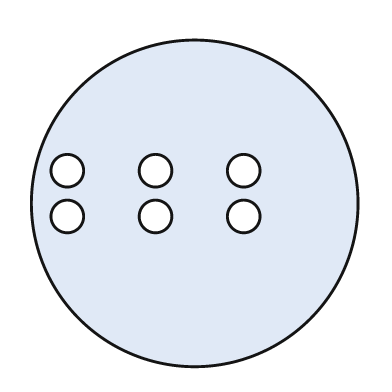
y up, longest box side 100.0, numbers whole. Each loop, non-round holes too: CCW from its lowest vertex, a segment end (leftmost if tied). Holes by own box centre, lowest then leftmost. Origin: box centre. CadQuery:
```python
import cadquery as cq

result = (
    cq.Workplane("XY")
    .moveTo(0.0, 0.0)
    .circle(50.0)
    .moveTo(-39.0, -4.0)
    .circle(5.0)
    .moveTo(-12.0, -4.0)
    .circle(5.0)
    .moveTo(15.0, -4.0)
    .circle(5.0)
    .moveTo(-39.0, 10.0)
    .circle(5.0)
    .moveTo(-12.0, 10.0)
    .circle(5.0)
    .moveTo(15.0, 10.0)
    .circle(5.0)
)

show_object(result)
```